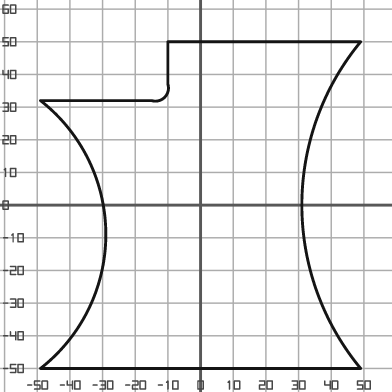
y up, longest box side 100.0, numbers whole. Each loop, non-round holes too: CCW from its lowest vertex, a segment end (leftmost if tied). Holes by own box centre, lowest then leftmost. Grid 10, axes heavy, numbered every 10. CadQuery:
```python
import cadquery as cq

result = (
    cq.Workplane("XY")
    .moveTo(-49.0, -50.0)
    .lineTo(49.0, -50.0)
    .threePointArc((31.0, 0.0), (49.0, 50.0))
    .lineTo(-10.0, 50.0)
    .lineTo(-10.0, 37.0)
    .threePointArc((-11.0, 33.0), (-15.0, 32.0))
    .lineTo(-49.0, 32.0)
    .threePointArc((-29.0, -9.0), (-49.0, -50.0))
    .close()
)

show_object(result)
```